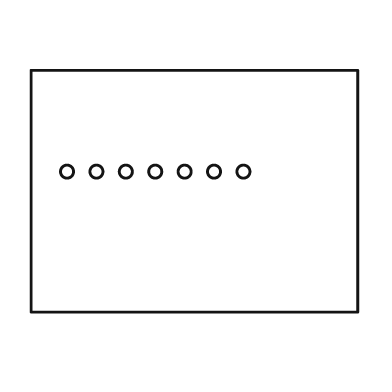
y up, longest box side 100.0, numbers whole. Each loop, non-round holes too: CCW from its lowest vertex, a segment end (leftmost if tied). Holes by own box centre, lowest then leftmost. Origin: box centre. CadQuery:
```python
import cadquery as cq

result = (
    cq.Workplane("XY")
    .moveTo(-50.0, -37.0)
    .lineTo(50.0, -37.0)
    .lineTo(50.0, 37.0)
    .lineTo(-50.0, 37.0)
    .close()
    .moveTo(-39.0, 6.0)
    .circle(2.0)
    .moveTo(-30.0, 6.0)
    .circle(2.0)
    .moveTo(-21.0, 6.0)
    .circle(2.0)
    .moveTo(-12.0, 6.0)
    .circle(2.0)
    .moveTo(-3.0, 6.0)
    .circle(2.0)
    .moveTo(6.0, 6.0)
    .circle(2.0)
    .moveTo(15.0, 6.0)
    .circle(2.0)
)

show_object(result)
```